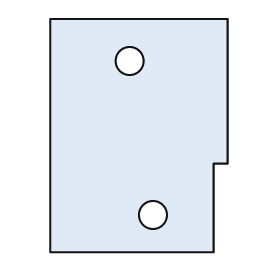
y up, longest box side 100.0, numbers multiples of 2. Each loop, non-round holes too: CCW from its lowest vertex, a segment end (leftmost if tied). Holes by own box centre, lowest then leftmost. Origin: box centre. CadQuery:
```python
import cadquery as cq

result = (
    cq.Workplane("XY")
    .moveTo(-38.0, -50.0)
    .lineTo(32.0, -50.0)
    .lineTo(32.0, -12.0)
    .lineTo(38.0, -12.0)
    .lineTo(38.0, 50.0)
    .lineTo(-38.0, 50.0)
    .close()
    .moveTo(6.0, -34.0)
    .circle(6.0)
    .moveTo(-4.0, 32.0)
    .circle(6.0)
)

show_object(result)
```